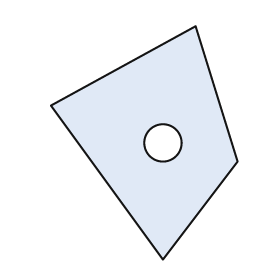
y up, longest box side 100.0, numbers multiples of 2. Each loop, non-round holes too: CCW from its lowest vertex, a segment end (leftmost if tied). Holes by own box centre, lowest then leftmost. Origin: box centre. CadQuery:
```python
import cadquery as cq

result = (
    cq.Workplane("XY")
    .moveTo(8.0, -50.0)
    .lineTo(40.0, -8.0)
    .lineTo(22.0, 50.0)
    .lineTo(-40.0, 16.0)
    .close()
    .moveTo(8.0, 0.0)
    .circle(8.0)
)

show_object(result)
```